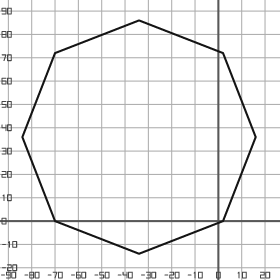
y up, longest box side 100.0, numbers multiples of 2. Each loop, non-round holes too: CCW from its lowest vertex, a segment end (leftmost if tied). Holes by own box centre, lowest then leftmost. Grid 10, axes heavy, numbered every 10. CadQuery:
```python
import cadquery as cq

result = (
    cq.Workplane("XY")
    .moveTo(-34.0, -14.0)
    .lineTo(2.0, 0.0)
    .lineTo(16.0, 36.0)
    .lineTo(2.0, 72.0)
    .lineTo(-34.0, 86.0)
    .lineTo(-70.0, 72.0)
    .lineTo(-84.0, 36.0)
    .lineTo(-70.0, 0.0)
    .close()
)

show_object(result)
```